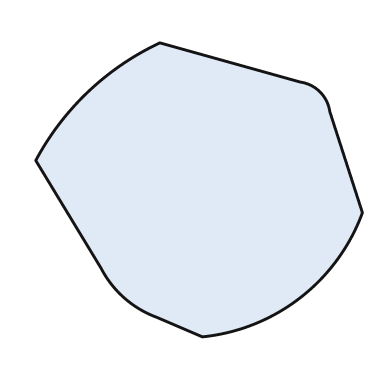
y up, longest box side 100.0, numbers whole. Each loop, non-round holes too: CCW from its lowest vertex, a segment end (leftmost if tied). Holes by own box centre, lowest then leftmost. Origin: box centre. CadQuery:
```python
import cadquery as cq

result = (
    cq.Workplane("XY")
    .moveTo(1.0, -45.0)
    .threePointArc((31.0, -33.0), (50.0, -7.0))
    .lineTo(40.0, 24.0)
    .threePointArc((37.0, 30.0), (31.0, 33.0))
    .lineTo(-12.0, 45.0)
    .threePointArc((-34.0, 30.0), (-50.0, 9.0))
    .lineTo(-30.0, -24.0)
    .threePointArc((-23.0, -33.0), (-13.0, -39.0))
    .close()
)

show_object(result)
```